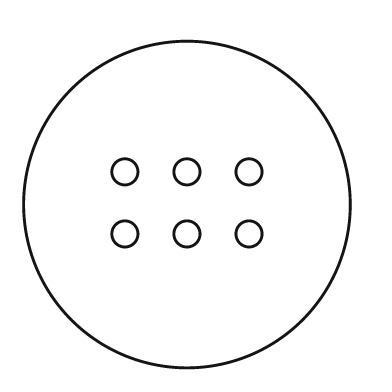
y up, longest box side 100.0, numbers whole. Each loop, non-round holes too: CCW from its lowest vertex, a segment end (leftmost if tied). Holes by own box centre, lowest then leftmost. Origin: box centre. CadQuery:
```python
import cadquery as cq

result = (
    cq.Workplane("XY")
    .moveTo(0.0, 0.0)
    .circle(50.0)
    .moveTo(-19.0, -9.0)
    .circle(4.0)
    .moveTo(0.0, -9.0)
    .circle(4.0)
    .moveTo(19.0, -9.0)
    .circle(4.0)
    .moveTo(-19.0, 10.0)
    .circle(4.0)
    .moveTo(0.0, 10.0)
    .circle(4.0)
    .moveTo(19.0, 10.0)
    .circle(4.0)
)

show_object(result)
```